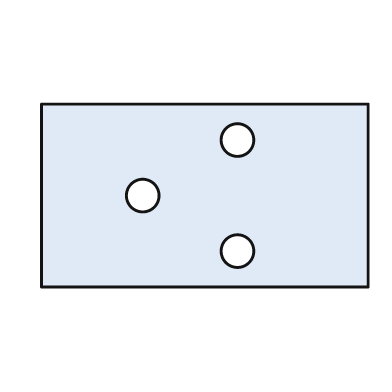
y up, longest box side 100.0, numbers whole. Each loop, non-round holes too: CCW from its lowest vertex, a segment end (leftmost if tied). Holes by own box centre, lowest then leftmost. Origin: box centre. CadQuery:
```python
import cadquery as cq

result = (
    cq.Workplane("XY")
    .moveTo(-50.0, -28.0)
    .lineTo(50.0, -28.0)
    .lineTo(50.0, 28.0)
    .lineTo(-50.0, 28.0)
    .close()
    .moveTo(10.0, -17.0)
    .circle(5.0)
    .moveTo(-19.0, 0.0)
    .circle(5.0)
    .moveTo(10.0, 17.0)
    .circle(5.0)
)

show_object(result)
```